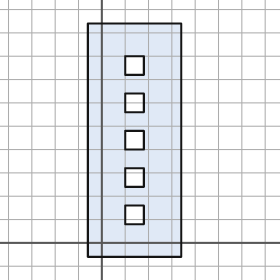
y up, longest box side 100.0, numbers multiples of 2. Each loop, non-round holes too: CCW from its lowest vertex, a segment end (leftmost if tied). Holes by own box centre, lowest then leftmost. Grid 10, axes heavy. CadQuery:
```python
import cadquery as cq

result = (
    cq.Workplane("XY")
    .moveTo(-6.0, -6.0)
    .lineTo(34.0, -6.0)
    .lineTo(34.0, 94.0)
    .lineTo(-6.0, 94.0)
    .close()
    .moveTo(10.0, 8.0)
    .lineTo(18.0, 8.0)
    .lineTo(18.0, 16.0)
    .lineTo(10.0, 16.0)
    .close()
    .moveTo(10.0, 24.0)
    .lineTo(18.0, 24.0)
    .lineTo(18.0, 32.0)
    .lineTo(10.0, 32.0)
    .close()
    .moveTo(10.0, 40.0)
    .lineTo(18.0, 40.0)
    .lineTo(18.0, 48.0)
    .lineTo(10.0, 48.0)
    .close()
    .moveTo(10.0, 56.0)
    .lineTo(18.0, 56.0)
    .lineTo(18.0, 64.0)
    .lineTo(10.0, 64.0)
    .close()
    .moveTo(10.0, 72.0)
    .lineTo(18.0, 72.0)
    .lineTo(18.0, 80.0)
    .lineTo(10.0, 80.0)
    .close()
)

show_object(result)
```